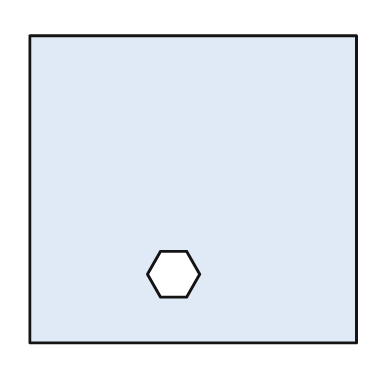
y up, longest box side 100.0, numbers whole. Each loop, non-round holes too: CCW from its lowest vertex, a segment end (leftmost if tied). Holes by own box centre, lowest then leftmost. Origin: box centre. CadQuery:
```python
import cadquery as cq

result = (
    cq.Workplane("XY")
    .moveTo(-50.0, -47.0)
    .lineTo(50.0, -47.0)
    .lineTo(50.0, 47.0)
    .lineTo(-50.0, 47.0)
    .close()
    .moveTo(-10.0, -33.0)
    .lineTo(-2.0, -33.0)
    .lineTo(2.0, -26.0)
    .lineTo(-2.0, -19.0)
    .lineTo(-10.0, -19.0)
    .lineTo(-14.0, -26.0)
    .close()
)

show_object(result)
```